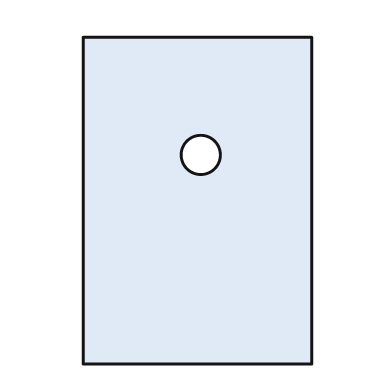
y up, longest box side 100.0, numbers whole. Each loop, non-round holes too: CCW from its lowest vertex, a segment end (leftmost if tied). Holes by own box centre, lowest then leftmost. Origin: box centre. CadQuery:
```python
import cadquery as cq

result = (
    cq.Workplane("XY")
    .moveTo(-35.0, -50.0)
    .lineTo(35.0, -50.0)
    .lineTo(35.0, 50.0)
    .lineTo(-35.0, 50.0)
    .close()
    .moveTo(1.0, 14.0)
    .circle(6.0)
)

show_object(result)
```